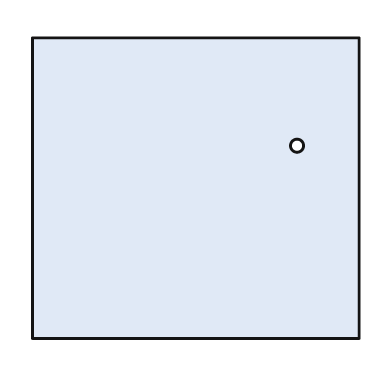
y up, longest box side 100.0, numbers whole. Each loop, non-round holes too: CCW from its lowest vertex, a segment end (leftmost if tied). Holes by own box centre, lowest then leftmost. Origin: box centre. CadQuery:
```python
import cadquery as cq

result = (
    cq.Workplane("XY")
    .moveTo(-50.0, -46.0)
    .lineTo(50.0, -46.0)
    .lineTo(50.0, 46.0)
    .lineTo(-50.0, 46.0)
    .close()
    .moveTo(31.0, 13.0)
    .circle(2.0)
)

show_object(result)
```